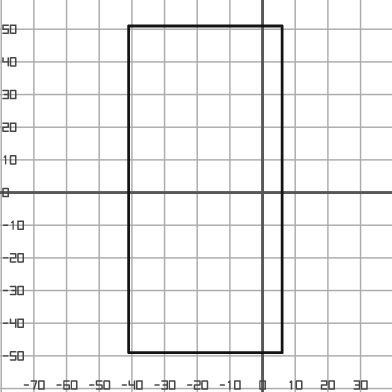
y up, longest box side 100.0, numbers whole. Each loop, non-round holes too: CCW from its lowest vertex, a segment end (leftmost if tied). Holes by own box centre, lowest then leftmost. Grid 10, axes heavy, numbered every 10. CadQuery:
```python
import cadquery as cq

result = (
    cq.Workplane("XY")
    .moveTo(-41.0, -49.0)
    .lineTo(6.0, -49.0)
    .lineTo(6.0, 51.0)
    .lineTo(-41.0, 51.0)
    .close()
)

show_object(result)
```